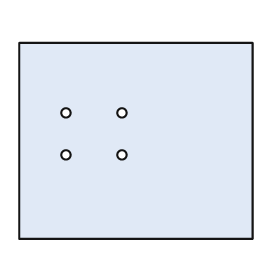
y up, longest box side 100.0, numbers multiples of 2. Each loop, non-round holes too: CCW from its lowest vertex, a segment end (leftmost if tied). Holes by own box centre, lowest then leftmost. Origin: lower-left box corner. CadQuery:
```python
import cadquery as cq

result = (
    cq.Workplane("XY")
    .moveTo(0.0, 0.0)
    .lineTo(100.0, 0.0)
    .lineTo(100.0, 84.0)
    .lineTo(0.0, 84.0)
    .close()
    .moveTo(20.0, 36.0)
    .circle(2.0)
    .moveTo(44.0, 36.0)
    .circle(2.0)
    .moveTo(20.0, 54.0)
    .circle(2.0)
    .moveTo(44.0, 54.0)
    .circle(2.0)
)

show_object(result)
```